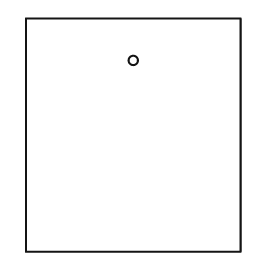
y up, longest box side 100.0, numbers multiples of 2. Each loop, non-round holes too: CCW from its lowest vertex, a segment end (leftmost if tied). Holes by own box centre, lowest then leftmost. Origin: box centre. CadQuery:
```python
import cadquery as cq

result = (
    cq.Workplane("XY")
    .moveTo(-46.0, -50.0)
    .lineTo(46.0, -50.0)
    .lineTo(46.0, 50.0)
    .lineTo(-46.0, 50.0)
    .close()
    .moveTo(0.0, 32.0)
    .circle(2.0)
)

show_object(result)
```